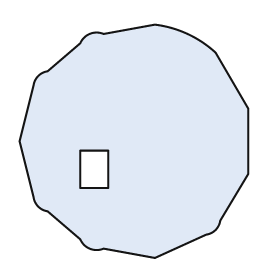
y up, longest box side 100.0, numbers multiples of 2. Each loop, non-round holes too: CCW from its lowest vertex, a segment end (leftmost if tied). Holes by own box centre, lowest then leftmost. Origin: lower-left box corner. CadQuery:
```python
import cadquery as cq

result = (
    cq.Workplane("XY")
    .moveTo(58.0, 0.0)
    .lineTo(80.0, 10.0)
    .threePointArc((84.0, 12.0), (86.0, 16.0))
    .lineTo(98.0, 36.0)
    .lineTo(98.0, 64.0)
    .lineTo(84.0, 88.0)
    .threePointArc((72.0, 96.0), (58.0, 100.0))
    .lineTo(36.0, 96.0)
    .threePointArc((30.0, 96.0), (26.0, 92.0))
    .lineTo(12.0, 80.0)
    .threePointArc((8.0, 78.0), (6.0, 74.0))
    .lineTo(0.0, 50.0)
    .lineTo(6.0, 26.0)
    .threePointArc((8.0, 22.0), (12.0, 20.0))
    .lineTo(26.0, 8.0)
    .threePointArc((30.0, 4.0), (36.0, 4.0))
    .close()
    .moveTo(26.0, 30.0)
    .lineTo(38.0, 30.0)
    .lineTo(38.0, 46.0)
    .lineTo(26.0, 46.0)
    .close()
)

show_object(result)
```